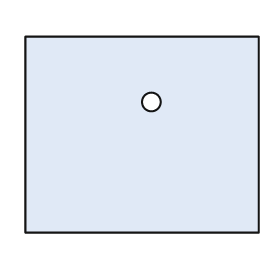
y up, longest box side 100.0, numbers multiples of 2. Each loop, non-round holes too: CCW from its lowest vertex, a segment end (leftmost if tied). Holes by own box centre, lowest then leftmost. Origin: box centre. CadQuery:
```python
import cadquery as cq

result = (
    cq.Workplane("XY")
    .moveTo(-50.0, -42.0)
    .lineTo(50.0, -42.0)
    .lineTo(50.0, 42.0)
    .lineTo(-50.0, 42.0)
    .close()
    .moveTo(4.0, 14.0)
    .circle(4.0)
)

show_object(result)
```